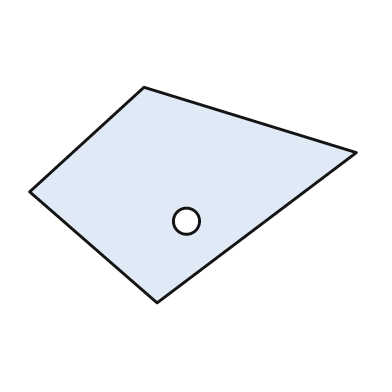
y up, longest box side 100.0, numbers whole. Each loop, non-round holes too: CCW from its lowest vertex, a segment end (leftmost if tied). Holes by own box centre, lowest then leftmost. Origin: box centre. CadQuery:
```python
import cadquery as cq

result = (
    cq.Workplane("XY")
    .moveTo(-11.0, -33.0)
    .lineTo(50.0, 13.0)
    .lineTo(-15.0, 33.0)
    .lineTo(-50.0, 1.0)
    .close()
    .moveTo(-2.0, -8.0)
    .circle(4.0)
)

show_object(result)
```